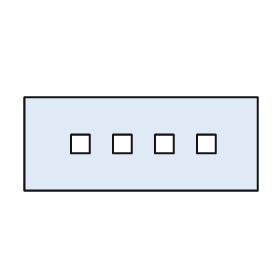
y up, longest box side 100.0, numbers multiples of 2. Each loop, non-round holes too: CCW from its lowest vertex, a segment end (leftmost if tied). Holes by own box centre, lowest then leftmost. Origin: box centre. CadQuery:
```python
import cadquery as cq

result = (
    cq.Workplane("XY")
    .moveTo(-50.0, -20.0)
    .lineTo(50.0, -20.0)
    .lineTo(50.0, 20.0)
    .lineTo(-50.0, 20.0)
    .close()
    .moveTo(-30.0, -4.0)
    .lineTo(-22.0, -4.0)
    .lineTo(-22.0, 4.0)
    .lineTo(-30.0, 4.0)
    .close()
    .moveTo(-12.0, -4.0)
    .lineTo(-4.0, -4.0)
    .lineTo(-4.0, 4.0)
    .lineTo(-12.0, 4.0)
    .close()
    .moveTo(6.0, -4.0)
    .lineTo(14.0, -4.0)
    .lineTo(14.0, 4.0)
    .lineTo(6.0, 4.0)
    .close()
    .moveTo(24.0, -4.0)
    .lineTo(32.0, -4.0)
    .lineTo(32.0, 4.0)
    .lineTo(24.0, 4.0)
    .close()
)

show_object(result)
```